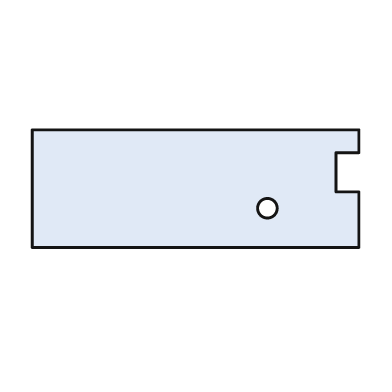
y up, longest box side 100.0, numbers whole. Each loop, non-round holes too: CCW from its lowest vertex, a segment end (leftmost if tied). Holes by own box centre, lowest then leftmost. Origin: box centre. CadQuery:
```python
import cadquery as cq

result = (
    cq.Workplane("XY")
    .moveTo(-50.0, -18.0)
    .lineTo(50.0, -18.0)
    .lineTo(50.0, -1.0)
    .lineTo(43.0, -1.0)
    .lineTo(43.0, 11.0)
    .lineTo(50.0, 11.0)
    .lineTo(50.0, 18.0)
    .lineTo(-50.0, 18.0)
    .close()
    .moveTo(22.0, -6.0)
    .circle(3.0)
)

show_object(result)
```